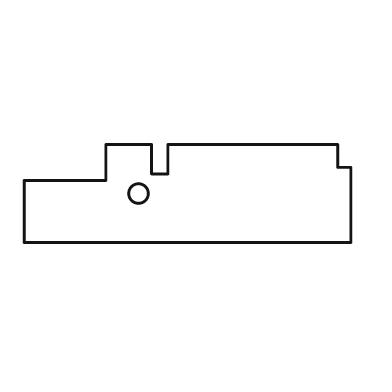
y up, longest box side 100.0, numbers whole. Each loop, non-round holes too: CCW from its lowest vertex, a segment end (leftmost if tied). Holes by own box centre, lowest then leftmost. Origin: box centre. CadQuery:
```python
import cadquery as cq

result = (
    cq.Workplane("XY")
    .moveTo(-50.0, -15.0)
    .lineTo(50.0, -15.0)
    .lineTo(50.0, 8.0)
    .lineTo(46.0, 8.0)
    .lineTo(46.0, 15.0)
    .lineTo(-6.0, 15.0)
    .lineTo(-6.0, 6.0)
    .lineTo(-11.0, 6.0)
    .lineTo(-11.0, 15.0)
    .lineTo(-25.0, 15.0)
    .lineTo(-25.0, 4.0)
    .lineTo(-50.0, 4.0)
    .close()
    .moveTo(-15.0, 0.0)
    .circle(3.0)
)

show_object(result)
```